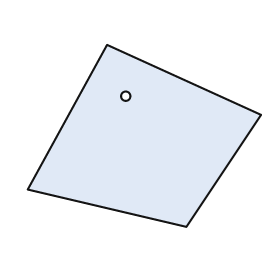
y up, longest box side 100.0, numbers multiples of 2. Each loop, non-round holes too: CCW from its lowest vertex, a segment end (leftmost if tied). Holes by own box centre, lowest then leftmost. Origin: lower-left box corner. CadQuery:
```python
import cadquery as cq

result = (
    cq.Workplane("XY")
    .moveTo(68.0, 0.0)
    .lineTo(100.0, 48.0)
    .lineTo(34.0, 78.0)
    .lineTo(0.0, 16.0)
    .close()
    .moveTo(42.0, 56.0)
    .circle(2.0)
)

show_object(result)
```